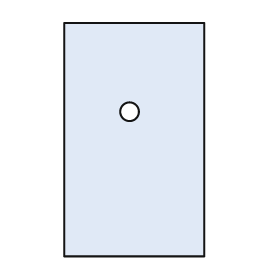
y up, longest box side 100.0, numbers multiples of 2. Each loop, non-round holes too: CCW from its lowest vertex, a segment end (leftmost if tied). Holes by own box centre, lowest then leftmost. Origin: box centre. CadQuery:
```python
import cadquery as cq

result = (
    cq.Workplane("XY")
    .moveTo(-30.0, -50.0)
    .lineTo(30.0, -50.0)
    .lineTo(30.0, 50.0)
    .lineTo(-30.0, 50.0)
    .close()
    .moveTo(-2.0, 12.0)
    .circle(4.0)
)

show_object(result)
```